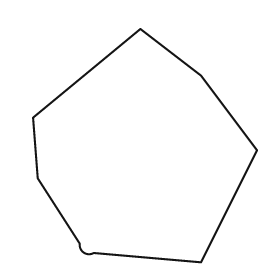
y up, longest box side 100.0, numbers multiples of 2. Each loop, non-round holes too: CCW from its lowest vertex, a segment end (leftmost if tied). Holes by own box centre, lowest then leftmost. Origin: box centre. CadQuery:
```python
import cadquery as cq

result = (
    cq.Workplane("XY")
    .moveTo(24.0, -50.0)
    .lineTo(48.0, -2.0)
    .lineTo(24.0, 30.0)
    .lineTo(-2.0, 50.0)
    .lineTo(-48.0, 12.0)
    .lineTo(-46.0, -14.0)
    .lineTo(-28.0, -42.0)
    .threePointArc((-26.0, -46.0), (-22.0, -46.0))
    .close()
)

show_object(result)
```